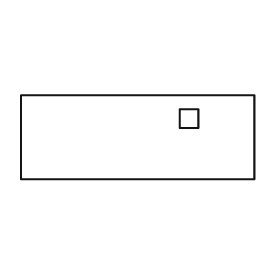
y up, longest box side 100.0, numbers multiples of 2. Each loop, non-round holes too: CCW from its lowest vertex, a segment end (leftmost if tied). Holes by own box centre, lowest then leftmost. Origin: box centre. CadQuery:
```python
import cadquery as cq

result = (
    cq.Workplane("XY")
    .moveTo(-50.0, -18.0)
    .lineTo(50.0, -18.0)
    .lineTo(50.0, 18.0)
    .lineTo(-50.0, 18.0)
    .close()
    .moveTo(18.0, 4.0)
    .lineTo(26.0, 4.0)
    .lineTo(26.0, 12.0)
    .lineTo(18.0, 12.0)
    .close()
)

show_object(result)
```